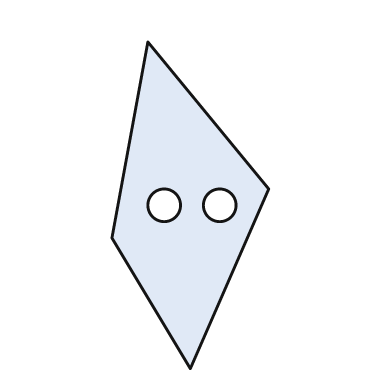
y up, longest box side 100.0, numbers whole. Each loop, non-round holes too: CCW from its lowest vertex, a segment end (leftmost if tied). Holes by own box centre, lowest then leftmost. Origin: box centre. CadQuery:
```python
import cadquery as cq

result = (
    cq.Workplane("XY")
    .moveTo(0.0, -50.0)
    .lineTo(24.0, 5.0)
    .lineTo(-13.0, 50.0)
    .lineTo(-24.0, -10.0)
    .close()
    .moveTo(-8.0, 0.0)
    .circle(5.0)
    .moveTo(9.0, 0.0)
    .circle(5.0)
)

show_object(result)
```